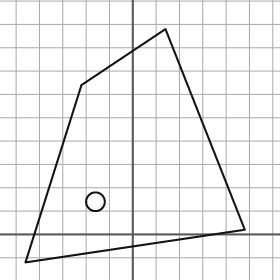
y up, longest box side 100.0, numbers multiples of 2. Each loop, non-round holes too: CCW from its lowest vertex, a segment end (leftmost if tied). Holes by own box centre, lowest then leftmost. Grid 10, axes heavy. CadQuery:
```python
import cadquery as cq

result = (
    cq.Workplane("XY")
    .moveTo(-46.0, -12.0)
    .lineTo(48.0, 2.0)
    .lineTo(14.0, 88.0)
    .lineTo(-22.0, 64.0)
    .close()
    .moveTo(-16.0, 14.0)
    .circle(4.0)
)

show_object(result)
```